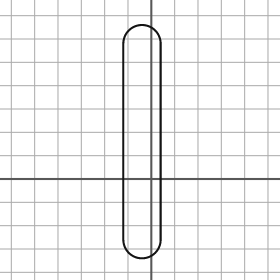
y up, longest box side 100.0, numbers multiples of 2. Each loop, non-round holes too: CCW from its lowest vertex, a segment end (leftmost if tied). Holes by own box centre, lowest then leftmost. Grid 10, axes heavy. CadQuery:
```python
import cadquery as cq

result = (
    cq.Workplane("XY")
    .moveTo(-12.0, -26.0)
    .threePointArc((-4.0, -34.0), (4.0, -26.0))
    .lineTo(4.0, 58.0)
    .threePointArc((-4.0, 66.0), (-12.0, 58.0))
    .close()
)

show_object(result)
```